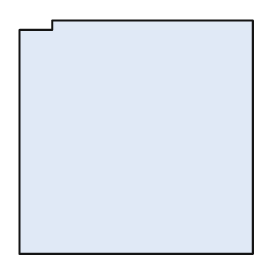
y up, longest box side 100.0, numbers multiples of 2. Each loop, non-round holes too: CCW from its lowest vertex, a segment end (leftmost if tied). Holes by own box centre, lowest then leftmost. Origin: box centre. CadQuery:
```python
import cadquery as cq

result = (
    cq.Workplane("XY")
    .moveTo(-50.0, -50.0)
    .lineTo(50.0, -50.0)
    .lineTo(50.0, 50.0)
    .lineTo(-36.0, 50.0)
    .lineTo(-36.0, 46.0)
    .lineTo(-50.0, 46.0)
    .close()
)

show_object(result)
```